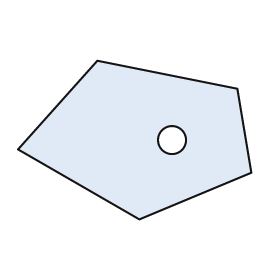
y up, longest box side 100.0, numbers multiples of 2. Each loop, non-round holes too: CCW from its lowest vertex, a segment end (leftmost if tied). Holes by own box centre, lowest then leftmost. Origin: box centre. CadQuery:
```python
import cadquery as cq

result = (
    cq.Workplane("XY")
    .moveTo(2.0, -34.0)
    .lineTo(50.0, -14.0)
    .lineTo(44.0, 22.0)
    .lineTo(-16.0, 34.0)
    .lineTo(-50.0, -4.0)
    .close()
    .moveTo(16.0, 0.0)
    .circle(6.0)
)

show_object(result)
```